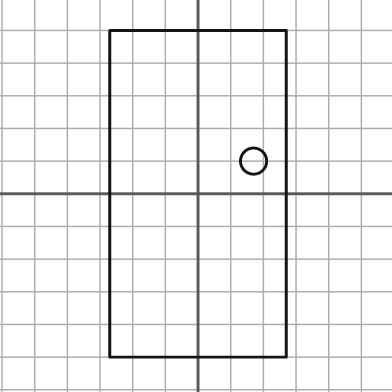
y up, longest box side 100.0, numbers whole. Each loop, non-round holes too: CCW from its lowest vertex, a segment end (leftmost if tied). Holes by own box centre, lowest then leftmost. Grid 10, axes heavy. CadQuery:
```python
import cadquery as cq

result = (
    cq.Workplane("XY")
    .moveTo(-27.0, -50.0)
    .lineTo(27.0, -50.0)
    .lineTo(27.0, 50.0)
    .lineTo(-27.0, 50.0)
    .close()
    .moveTo(17.0, 10.0)
    .circle(4.0)
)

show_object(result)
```